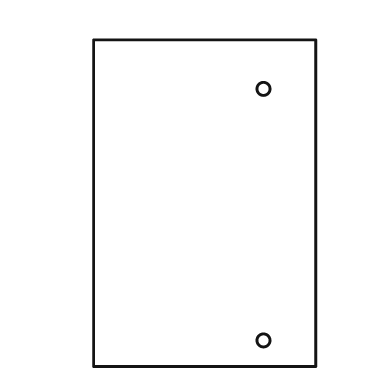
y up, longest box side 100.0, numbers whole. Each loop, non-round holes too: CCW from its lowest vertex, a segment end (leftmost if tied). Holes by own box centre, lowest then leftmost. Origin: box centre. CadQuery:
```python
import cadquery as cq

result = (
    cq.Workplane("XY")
    .moveTo(-34.0, -50.0)
    .lineTo(34.0, -50.0)
    .lineTo(34.0, 50.0)
    .lineTo(-34.0, 50.0)
    .close()
    .moveTo(18.0, -42.0)
    .circle(2.0)
    .moveTo(18.0, 35.0)
    .circle(2.0)
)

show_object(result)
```